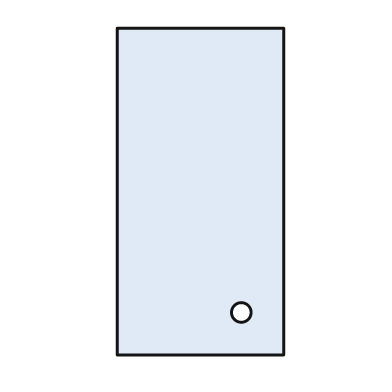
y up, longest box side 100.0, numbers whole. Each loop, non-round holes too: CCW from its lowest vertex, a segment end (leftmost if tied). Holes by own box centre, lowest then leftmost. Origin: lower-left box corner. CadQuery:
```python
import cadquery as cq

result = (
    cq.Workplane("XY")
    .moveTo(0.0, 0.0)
    .lineTo(51.0, 0.0)
    .lineTo(51.0, 100.0)
    .lineTo(0.0, 100.0)
    .close()
    .moveTo(38.0, 13.0)
    .circle(3.0)
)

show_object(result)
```